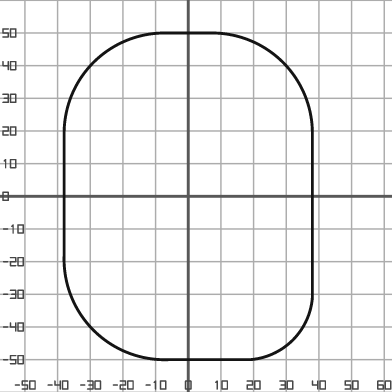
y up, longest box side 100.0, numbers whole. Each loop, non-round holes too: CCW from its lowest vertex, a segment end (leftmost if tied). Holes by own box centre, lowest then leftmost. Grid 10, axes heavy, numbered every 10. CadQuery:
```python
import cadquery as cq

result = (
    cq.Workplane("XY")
    .moveTo(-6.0, -50.0)
    .lineTo(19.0, -50.0)
    .threePointArc((32.0, -44.0), (38.0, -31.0))
    .lineTo(38.0, 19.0)
    .threePointArc((29.0, 41.0), (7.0, 50.0))
    .lineTo(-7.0, 50.0)
    .threePointArc((-29.0, 41.0), (-38.0, 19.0))
    .lineTo(-38.0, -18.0)
    .threePointArc((-29.0, -41.0), (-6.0, -50.0))
    .close()
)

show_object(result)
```